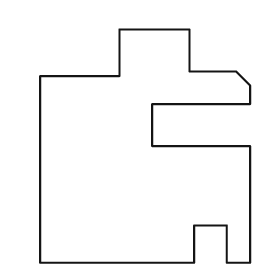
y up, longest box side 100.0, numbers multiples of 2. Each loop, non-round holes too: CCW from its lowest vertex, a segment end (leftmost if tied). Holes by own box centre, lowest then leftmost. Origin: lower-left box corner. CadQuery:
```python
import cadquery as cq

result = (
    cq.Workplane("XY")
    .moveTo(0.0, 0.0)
    .lineTo(66.0, 0.0)
    .lineTo(66.0, 16.0)
    .lineTo(80.0, 16.0)
    .lineTo(80.0, 0.0)
    .lineTo(90.0, 0.0)
    .lineTo(90.0, 50.0)
    .lineTo(48.0, 50.0)
    .lineTo(48.0, 68.0)
    .lineTo(90.0, 68.0)
    .lineTo(90.0, 76.0)
    .lineTo(84.0, 82.0)
    .lineTo(64.0, 82.0)
    .lineTo(64.0, 100.0)
    .lineTo(34.0, 100.0)
    .lineTo(34.0, 80.0)
    .lineTo(0.0, 80.0)
    .close()
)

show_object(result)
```